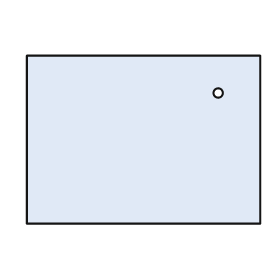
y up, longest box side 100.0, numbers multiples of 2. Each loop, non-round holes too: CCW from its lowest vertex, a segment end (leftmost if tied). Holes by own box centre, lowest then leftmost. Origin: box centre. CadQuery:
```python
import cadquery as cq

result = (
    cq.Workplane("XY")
    .moveTo(-50.0, -36.0)
    .lineTo(50.0, -36.0)
    .lineTo(50.0, 36.0)
    .lineTo(-50.0, 36.0)
    .close()
    .moveTo(32.0, 20.0)
    .circle(2.0)
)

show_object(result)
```